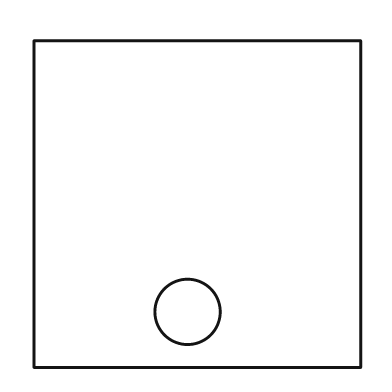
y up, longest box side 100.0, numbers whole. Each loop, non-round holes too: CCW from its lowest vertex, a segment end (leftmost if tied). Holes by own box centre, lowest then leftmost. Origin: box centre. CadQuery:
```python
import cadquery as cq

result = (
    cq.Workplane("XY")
    .moveTo(-50.0, -50.0)
    .lineTo(50.0, -50.0)
    .lineTo(50.0, 50.0)
    .lineTo(-50.0, 50.0)
    .close()
    .moveTo(-3.0, -33.0)
    .circle(10.0)
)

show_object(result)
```